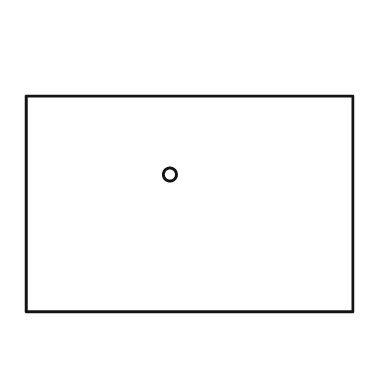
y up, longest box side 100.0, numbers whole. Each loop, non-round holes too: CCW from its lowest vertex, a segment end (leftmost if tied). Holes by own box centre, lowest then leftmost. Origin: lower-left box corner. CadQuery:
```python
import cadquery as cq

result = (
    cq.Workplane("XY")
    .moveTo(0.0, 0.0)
    .lineTo(100.0, 0.0)
    .lineTo(100.0, 66.0)
    .lineTo(0.0, 66.0)
    .close()
    .moveTo(44.0, 42.0)
    .circle(2.0)
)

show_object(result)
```